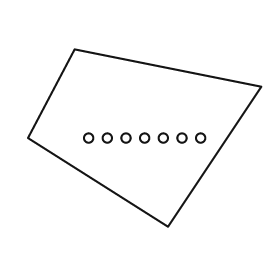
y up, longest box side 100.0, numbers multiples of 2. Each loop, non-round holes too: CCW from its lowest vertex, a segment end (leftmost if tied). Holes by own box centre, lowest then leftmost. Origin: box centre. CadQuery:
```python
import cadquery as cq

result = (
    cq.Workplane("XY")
    .moveTo(10.0, -38.0)
    .lineTo(50.0, 22.0)
    .lineTo(-30.0, 38.0)
    .lineTo(-50.0, 0.0)
    .close()
    .moveTo(-24.0, 0.0)
    .circle(2.0)
    .moveTo(-16.0, 0.0)
    .circle(2.0)
    .moveTo(-8.0, 0.0)
    .circle(2.0)
    .moveTo(0.0, 0.0)
    .circle(2.0)
    .moveTo(8.0, 0.0)
    .circle(2.0)
    .moveTo(16.0, 0.0)
    .circle(2.0)
    .moveTo(24.0, 0.0)
    .circle(2.0)
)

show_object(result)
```